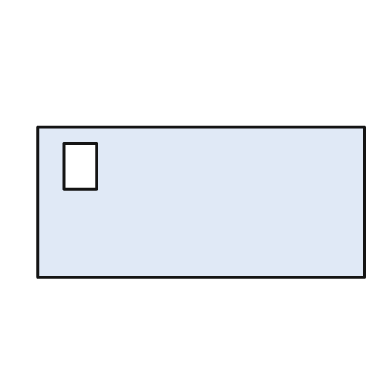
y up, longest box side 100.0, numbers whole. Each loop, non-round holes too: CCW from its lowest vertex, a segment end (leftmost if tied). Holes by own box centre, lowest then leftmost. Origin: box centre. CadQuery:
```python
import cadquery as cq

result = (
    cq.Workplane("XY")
    .moveTo(-50.0, -23.0)
    .lineTo(50.0, -23.0)
    .lineTo(50.0, 23.0)
    .lineTo(-50.0, 23.0)
    .close()
    .moveTo(-42.0, 4.0)
    .lineTo(-32.0, 4.0)
    .lineTo(-32.0, 18.0)
    .lineTo(-42.0, 18.0)
    .close()
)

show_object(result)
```